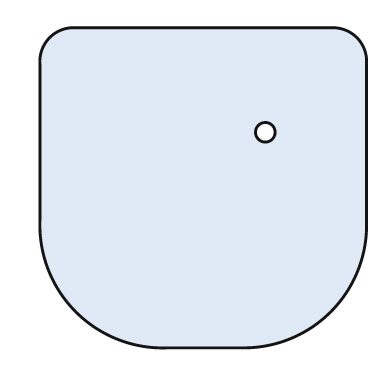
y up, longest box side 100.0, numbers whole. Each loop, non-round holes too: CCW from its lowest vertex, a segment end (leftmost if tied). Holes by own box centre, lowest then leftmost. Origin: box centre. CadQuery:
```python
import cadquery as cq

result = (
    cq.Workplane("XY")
    .moveTo(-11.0, -49.0)
    .lineTo(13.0, -49.0)
    .threePointArc((39.0, -38.0), (50.0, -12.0))
    .lineTo(50.0, 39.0)
    .threePointArc((47.0, 46.0), (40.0, 49.0))
    .lineTo(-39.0, 49.0)
    .threePointArc((-47.0, 46.0), (-50.0, 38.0))
    .lineTo(-50.0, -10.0)
    .threePointArc((-39.0, -38.0), (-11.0, -49.0))
    .close()
    .moveTo(19.0, 17.0)
    .circle(3.0)
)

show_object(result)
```